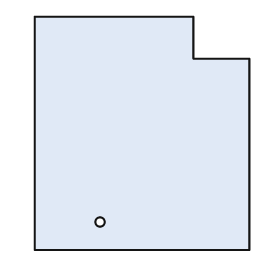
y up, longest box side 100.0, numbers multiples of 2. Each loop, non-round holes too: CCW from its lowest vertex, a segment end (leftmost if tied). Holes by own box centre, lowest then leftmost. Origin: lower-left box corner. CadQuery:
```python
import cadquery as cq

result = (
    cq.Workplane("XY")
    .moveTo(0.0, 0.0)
    .lineTo(92.0, 0.0)
    .lineTo(92.0, 82.0)
    .lineTo(68.0, 82.0)
    .lineTo(68.0, 100.0)
    .lineTo(0.0, 100.0)
    .close()
    .moveTo(28.0, 12.0)
    .circle(2.0)
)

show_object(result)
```